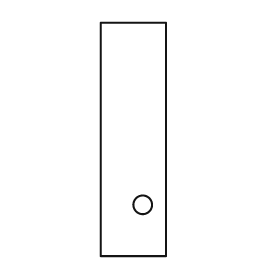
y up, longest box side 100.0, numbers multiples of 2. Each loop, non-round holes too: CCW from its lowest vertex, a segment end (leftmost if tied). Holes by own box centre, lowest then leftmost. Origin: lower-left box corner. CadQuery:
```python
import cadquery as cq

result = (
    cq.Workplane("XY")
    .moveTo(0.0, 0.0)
    .lineTo(28.0, 0.0)
    .lineTo(28.0, 100.0)
    .lineTo(0.0, 100.0)
    .close()
    .moveTo(18.0, 22.0)
    .circle(4.0)
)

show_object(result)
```